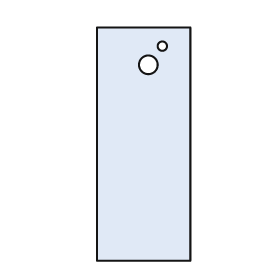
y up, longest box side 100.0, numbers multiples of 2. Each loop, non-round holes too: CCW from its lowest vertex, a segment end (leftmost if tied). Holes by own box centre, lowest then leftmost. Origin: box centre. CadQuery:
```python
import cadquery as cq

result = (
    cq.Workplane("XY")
    .moveTo(-20.0, -50.0)
    .lineTo(20.0, -50.0)
    .lineTo(20.0, 50.0)
    .lineTo(-20.0, 50.0)
    .close()
    .moveTo(2.0, 34.0)
    .circle(4.0)
    .moveTo(8.0, 42.0)
    .circle(2.0)
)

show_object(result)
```